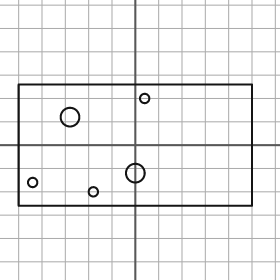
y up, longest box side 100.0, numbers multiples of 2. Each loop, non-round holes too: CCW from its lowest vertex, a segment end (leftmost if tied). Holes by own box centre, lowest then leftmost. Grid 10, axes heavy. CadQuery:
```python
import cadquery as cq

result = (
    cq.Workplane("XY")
    .moveTo(-50.0, -26.0)
    .lineTo(50.0, -26.0)
    .lineTo(50.0, 26.0)
    .lineTo(-50.0, 26.0)
    .close()
    .moveTo(-18.0, -20.0)
    .circle(2.0)
    .moveTo(-44.0, -16.0)
    .circle(2.0)
    .moveTo(0.0, -12.0)
    .circle(4.0)
    .moveTo(-28.0, 12.0)
    .circle(4.0)
    .moveTo(4.0, 20.0)
    .circle(2.0)
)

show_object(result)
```